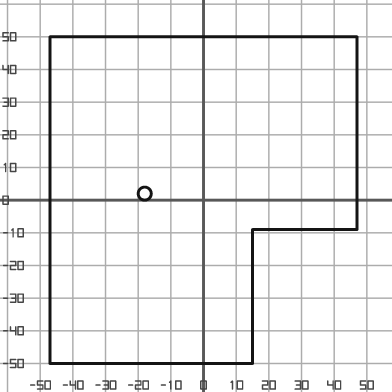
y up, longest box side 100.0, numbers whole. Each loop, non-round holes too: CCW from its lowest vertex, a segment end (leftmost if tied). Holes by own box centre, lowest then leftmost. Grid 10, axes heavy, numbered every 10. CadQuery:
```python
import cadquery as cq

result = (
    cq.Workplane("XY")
    .moveTo(-47.0, -50.0)
    .lineTo(15.0, -50.0)
    .lineTo(15.0, -9.0)
    .lineTo(47.0, -9.0)
    .lineTo(47.0, 50.0)
    .lineTo(-47.0, 50.0)
    .close()
    .moveTo(-18.0, 2.0)
    .circle(2.0)
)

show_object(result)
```